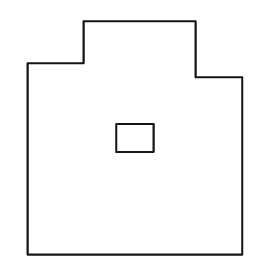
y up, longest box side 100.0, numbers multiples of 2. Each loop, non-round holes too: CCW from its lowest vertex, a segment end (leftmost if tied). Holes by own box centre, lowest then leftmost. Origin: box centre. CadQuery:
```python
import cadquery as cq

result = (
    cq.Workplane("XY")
    .moveTo(-46.0, -50.0)
    .lineTo(46.0, -50.0)
    .lineTo(46.0, 26.0)
    .lineTo(26.0, 26.0)
    .lineTo(26.0, 50.0)
    .lineTo(-22.0, 50.0)
    .lineTo(-22.0, 32.0)
    .lineTo(-46.0, 32.0)
    .close()
    .moveTo(-8.0, -6.0)
    .lineTo(8.0, -6.0)
    .lineTo(8.0, 6.0)
    .lineTo(-8.0, 6.0)
    .close()
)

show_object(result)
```